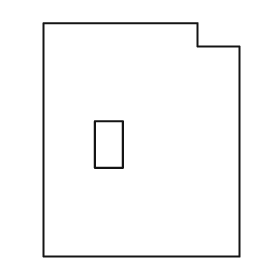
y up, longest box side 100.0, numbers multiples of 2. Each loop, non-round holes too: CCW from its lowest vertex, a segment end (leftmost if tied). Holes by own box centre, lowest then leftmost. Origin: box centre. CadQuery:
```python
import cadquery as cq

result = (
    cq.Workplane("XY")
    .moveTo(-42.0, -50.0)
    .lineTo(42.0, -50.0)
    .lineTo(42.0, 40.0)
    .lineTo(24.0, 40.0)
    .lineTo(24.0, 50.0)
    .lineTo(-42.0, 50.0)
    .close()
    .moveTo(-20.0, -12.0)
    .lineTo(-8.0, -12.0)
    .lineTo(-8.0, 8.0)
    .lineTo(-20.0, 8.0)
    .close()
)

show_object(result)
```